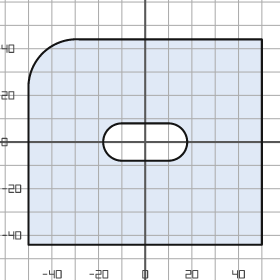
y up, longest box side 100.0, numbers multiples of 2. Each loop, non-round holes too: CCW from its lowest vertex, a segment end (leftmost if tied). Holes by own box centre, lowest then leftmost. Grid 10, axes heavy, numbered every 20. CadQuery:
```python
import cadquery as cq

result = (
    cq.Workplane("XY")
    .moveTo(-50.0, -44.0)
    .lineTo(50.0, -44.0)
    .lineTo(50.0, 44.0)
    .lineTo(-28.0, 44.0)
    .threePointArc((-44.0, 38.0), (-50.0, 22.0))
    .close()
    .moveTo(-10.0, -8.0)
    .lineTo(10.0, -8.0)
    .threePointArc((18.0, 0.0), (10.0, 8.0))
    .lineTo(-10.0, 8.0)
    .threePointArc((-18.0, 0.0), (-10.0, -8.0))
    .close()
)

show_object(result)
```